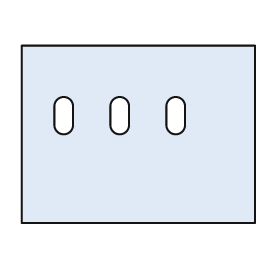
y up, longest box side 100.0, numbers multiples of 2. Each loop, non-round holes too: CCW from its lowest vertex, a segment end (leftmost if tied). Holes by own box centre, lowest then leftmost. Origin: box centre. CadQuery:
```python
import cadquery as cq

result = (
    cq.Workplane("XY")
    .moveTo(-50.0, -38.0)
    .lineTo(50.0, -38.0)
    .lineTo(50.0, 38.0)
    .lineTo(-50.0, 38.0)
    .close()
    .moveTo(-36.0, 4.0)
    .threePointArc((-32.0, 0.0), (-28.0, 4.0))
    .lineTo(-28.0, 12.0)
    .threePointArc((-32.0, 16.0), (-36.0, 12.0))
    .close()
    .moveTo(-12.0, 4.0)
    .threePointArc((-8.0, 0.0), (-4.0, 4.0))
    .lineTo(-4.0, 12.0)
    .threePointArc((-8.0, 16.0), (-12.0, 12.0))
    .close()
    .moveTo(12.0, 4.0)
    .threePointArc((16.0, 0.0), (20.0, 4.0))
    .lineTo(20.0, 12.0)
    .threePointArc((16.0, 16.0), (12.0, 12.0))
    .close()
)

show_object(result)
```